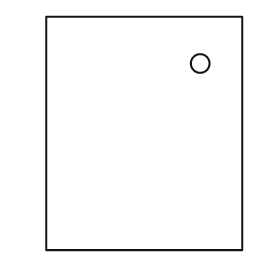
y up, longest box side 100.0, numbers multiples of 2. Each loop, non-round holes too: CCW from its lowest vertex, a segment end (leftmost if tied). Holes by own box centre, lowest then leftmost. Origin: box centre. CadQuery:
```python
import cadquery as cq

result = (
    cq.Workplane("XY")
    .moveTo(-42.0, -50.0)
    .lineTo(42.0, -50.0)
    .lineTo(42.0, 50.0)
    .lineTo(-42.0, 50.0)
    .close()
    .moveTo(24.0, 30.0)
    .circle(4.0)
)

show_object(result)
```